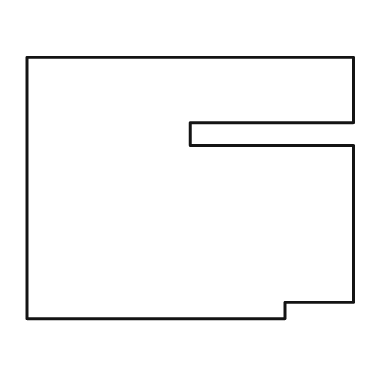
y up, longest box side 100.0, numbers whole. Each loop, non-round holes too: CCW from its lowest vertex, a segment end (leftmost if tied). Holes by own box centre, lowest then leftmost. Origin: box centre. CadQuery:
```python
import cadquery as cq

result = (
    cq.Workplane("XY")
    .moveTo(-50.0, -40.0)
    .lineTo(29.0, -40.0)
    .lineTo(29.0, -35.0)
    .lineTo(50.0, -35.0)
    .lineTo(50.0, 13.0)
    .lineTo(0.0, 13.0)
    .lineTo(0.0, 20.0)
    .lineTo(50.0, 20.0)
    .lineTo(50.0, 40.0)
    .lineTo(-50.0, 40.0)
    .close()
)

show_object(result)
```